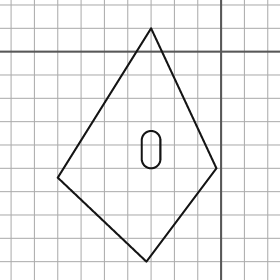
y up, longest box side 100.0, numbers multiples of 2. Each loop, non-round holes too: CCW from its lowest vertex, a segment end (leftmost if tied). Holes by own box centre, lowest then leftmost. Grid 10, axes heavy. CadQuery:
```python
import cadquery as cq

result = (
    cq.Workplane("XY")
    .moveTo(-32.0, -90.0)
    .lineTo(-2.0, -50.0)
    .lineTo(-30.0, 10.0)
    .lineTo(-70.0, -54.0)
    .close()
    .moveTo(-34.0, -46.0)
    .threePointArc((-30.0, -50.0), (-26.0, -46.0))
    .lineTo(-26.0, -38.0)
    .threePointArc((-30.0, -34.0), (-34.0, -38.0))
    .close()
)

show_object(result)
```